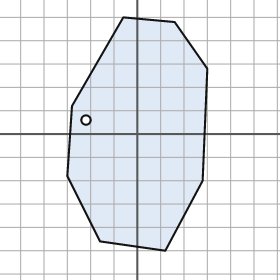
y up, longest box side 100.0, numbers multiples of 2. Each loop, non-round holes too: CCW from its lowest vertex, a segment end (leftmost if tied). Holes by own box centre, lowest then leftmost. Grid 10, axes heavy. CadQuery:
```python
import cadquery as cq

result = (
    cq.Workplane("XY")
    .moveTo(12.0, -50.0)
    .lineTo(28.0, -20.0)
    .lineTo(30.0, 28.0)
    .lineTo(16.0, 48.0)
    .lineTo(-6.0, 50.0)
    .lineTo(-28.0, 12.0)
    .lineTo(-30.0, -18.0)
    .lineTo(-16.0, -46.0)
    .close()
    .moveTo(-22.0, 6.0)
    .circle(2.0)
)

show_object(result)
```